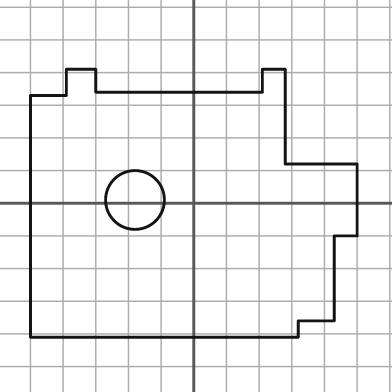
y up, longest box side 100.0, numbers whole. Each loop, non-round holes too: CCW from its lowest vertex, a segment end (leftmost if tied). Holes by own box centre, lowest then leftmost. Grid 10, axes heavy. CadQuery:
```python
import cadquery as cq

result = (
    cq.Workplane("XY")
    .moveTo(-50.0, -41.0)
    .lineTo(32.0, -41.0)
    .lineTo(32.0, -36.0)
    .lineTo(43.0, -36.0)
    .lineTo(43.0, -10.0)
    .lineTo(50.0, -10.0)
    .lineTo(50.0, 12.0)
    .lineTo(28.0, 12.0)
    .lineTo(28.0, 41.0)
    .lineTo(21.0, 41.0)
    .lineTo(21.0, 34.0)
    .lineTo(-30.0, 34.0)
    .lineTo(-30.0, 41.0)
    .lineTo(-39.0, 41.0)
    .lineTo(-39.0, 33.0)
    .lineTo(-50.0, 33.0)
    .close()
    .moveTo(-18.0, 1.0)
    .circle(9.0)
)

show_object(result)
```